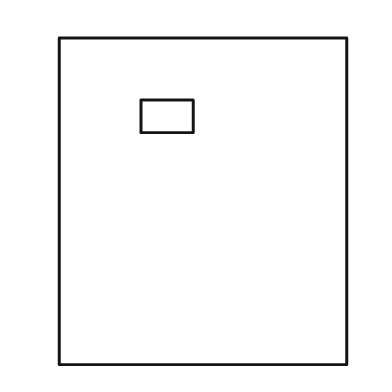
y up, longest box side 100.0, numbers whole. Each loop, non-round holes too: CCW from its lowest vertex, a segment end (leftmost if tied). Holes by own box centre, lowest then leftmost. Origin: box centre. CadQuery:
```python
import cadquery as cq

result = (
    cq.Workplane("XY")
    .moveTo(-44.0, -50.0)
    .lineTo(44.0, -50.0)
    .lineTo(44.0, 50.0)
    .lineTo(-44.0, 50.0)
    .close()
    .moveTo(-19.0, 21.0)
    .lineTo(-3.0, 21.0)
    .lineTo(-3.0, 31.0)
    .lineTo(-19.0, 31.0)
    .close()
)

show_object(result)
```